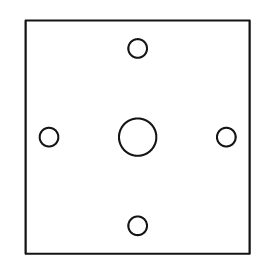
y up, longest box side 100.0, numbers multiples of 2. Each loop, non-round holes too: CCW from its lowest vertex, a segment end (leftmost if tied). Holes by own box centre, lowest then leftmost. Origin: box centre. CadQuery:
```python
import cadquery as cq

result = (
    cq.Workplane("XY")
    .moveTo(-48.0, -50.0)
    .lineTo(48.0, -50.0)
    .lineTo(48.0, 50.0)
    .lineTo(-48.0, 50.0)
    .close()
    .moveTo(0.0, -38.0)
    .circle(4.0)
    .moveTo(-38.0, 0.0)
    .circle(4.0)
    .moveTo(0.0, 0.0)
    .circle(8.0)
    .moveTo(38.0, 0.0)
    .circle(4.0)
    .moveTo(0.0, 38.0)
    .circle(4.0)
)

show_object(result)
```